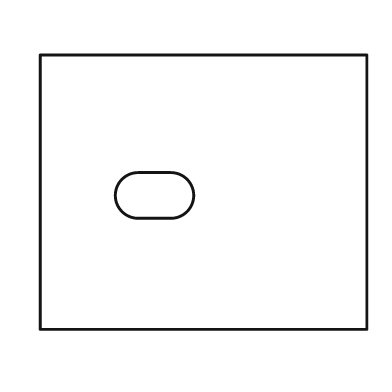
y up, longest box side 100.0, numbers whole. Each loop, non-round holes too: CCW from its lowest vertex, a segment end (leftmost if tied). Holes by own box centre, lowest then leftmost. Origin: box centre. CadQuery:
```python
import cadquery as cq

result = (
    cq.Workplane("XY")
    .moveTo(-50.0, -42.0)
    .lineTo(50.0, -42.0)
    .lineTo(50.0, 42.0)
    .lineTo(-50.0, 42.0)
    .close()
    .moveTo(-20.0, -8.0)
    .lineTo(-10.0, -8.0)
    .threePointArc((-3.0, -1.0), (-10.0, 6.0))
    .lineTo(-20.0, 6.0)
    .threePointArc((-27.0, -1.0), (-20.0, -8.0))
    .close()
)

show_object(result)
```